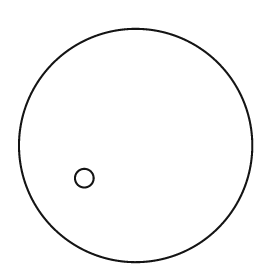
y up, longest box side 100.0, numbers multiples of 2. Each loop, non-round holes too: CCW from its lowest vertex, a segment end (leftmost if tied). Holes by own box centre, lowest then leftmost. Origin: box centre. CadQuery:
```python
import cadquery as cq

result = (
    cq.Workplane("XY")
    .moveTo(0.0, 0.0)
    .circle(50.0)
    .moveTo(-22.0, -14.0)
    .circle(4.0)
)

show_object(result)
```